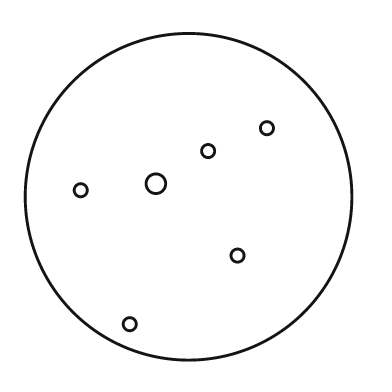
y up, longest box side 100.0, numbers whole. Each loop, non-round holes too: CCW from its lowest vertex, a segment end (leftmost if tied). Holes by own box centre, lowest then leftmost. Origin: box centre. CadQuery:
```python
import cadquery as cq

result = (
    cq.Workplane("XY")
    .moveTo(0.0, 0.0)
    .circle(50.0)
    .moveTo(-18.0, -39.0)
    .circle(2.0)
    .moveTo(15.0, -18.0)
    .circle(2.0)
    .moveTo(-33.0, 2.0)
    .circle(2.0)
    .moveTo(-10.0, 4.0)
    .circle(3.0)
    .moveTo(6.0, 14.0)
    .circle(2.0)
    .moveTo(24.0, 21.0)
    .circle(2.0)
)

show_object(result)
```